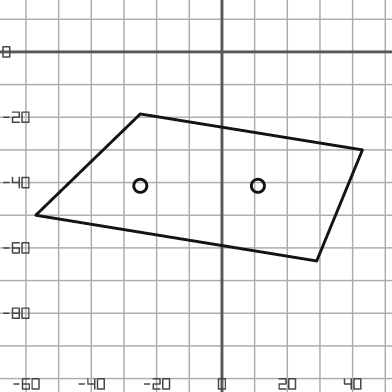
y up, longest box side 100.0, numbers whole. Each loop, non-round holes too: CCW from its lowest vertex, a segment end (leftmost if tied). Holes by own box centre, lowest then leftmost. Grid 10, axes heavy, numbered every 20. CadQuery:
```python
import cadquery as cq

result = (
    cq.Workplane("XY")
    .moveTo(29.0, -64.0)
    .lineTo(43.0, -30.0)
    .lineTo(-25.0, -19.0)
    .lineTo(-57.0, -50.0)
    .close()
    .moveTo(-25.0, -41.0)
    .circle(2.0)
    .moveTo(11.0, -41.0)
    .circle(2.0)
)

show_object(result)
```